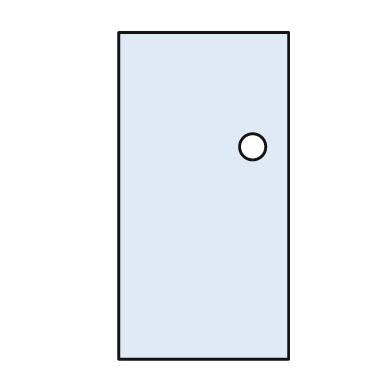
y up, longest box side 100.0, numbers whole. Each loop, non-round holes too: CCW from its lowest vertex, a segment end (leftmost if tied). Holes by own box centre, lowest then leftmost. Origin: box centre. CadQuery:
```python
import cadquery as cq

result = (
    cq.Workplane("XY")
    .moveTo(-26.0, -50.0)
    .lineTo(26.0, -50.0)
    .lineTo(26.0, 50.0)
    .lineTo(-26.0, 50.0)
    .close()
    .moveTo(15.0, 15.0)
    .circle(4.0)
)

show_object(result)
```